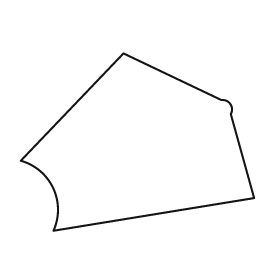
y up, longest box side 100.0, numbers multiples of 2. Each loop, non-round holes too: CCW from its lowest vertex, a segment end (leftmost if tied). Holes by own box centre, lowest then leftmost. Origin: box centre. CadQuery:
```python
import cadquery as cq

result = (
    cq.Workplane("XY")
    .moveTo(-36.0, -38.0)
    .lineTo(50.0, -24.0)
    .lineTo(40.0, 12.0)
    .threePointArc((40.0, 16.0), (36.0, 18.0))
    .lineTo(-6.0, 38.0)
    .lineTo(-50.0, -8.0)
    .threePointArc((-36.0, -20.0), (-36.0, -38.0))
    .close()
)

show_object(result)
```